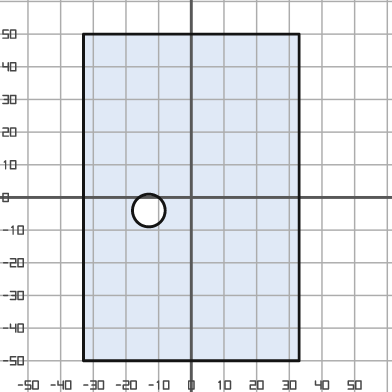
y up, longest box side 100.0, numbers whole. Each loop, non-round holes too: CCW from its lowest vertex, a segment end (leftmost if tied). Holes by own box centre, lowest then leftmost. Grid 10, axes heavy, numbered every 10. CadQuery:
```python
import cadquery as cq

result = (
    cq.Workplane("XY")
    .moveTo(-33.0, -50.0)
    .lineTo(33.0, -50.0)
    .lineTo(33.0, 50.0)
    .lineTo(-33.0, 50.0)
    .close()
    .moveTo(-13.0, -4.0)
    .circle(5.0)
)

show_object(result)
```